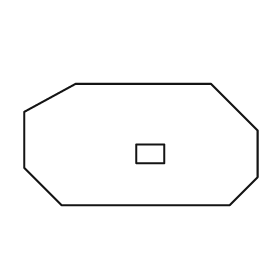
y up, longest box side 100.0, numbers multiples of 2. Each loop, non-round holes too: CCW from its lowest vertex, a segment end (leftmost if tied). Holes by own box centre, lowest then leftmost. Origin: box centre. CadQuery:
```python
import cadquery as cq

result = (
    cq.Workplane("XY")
    .moveTo(-34.0, -26.0)
    .lineTo(38.0, -26.0)
    .lineTo(50.0, -14.0)
    .lineTo(50.0, 6.0)
    .lineTo(30.0, 26.0)
    .lineTo(-28.0, 26.0)
    .lineTo(-50.0, 14.0)
    .lineTo(-50.0, -10.0)
    .close()
    .moveTo(-2.0, -8.0)
    .lineTo(10.0, -8.0)
    .lineTo(10.0, 0.0)
    .lineTo(-2.0, 0.0)
    .close()
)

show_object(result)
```